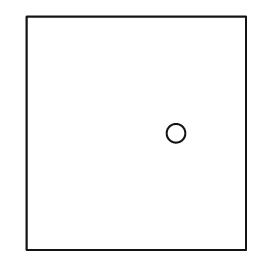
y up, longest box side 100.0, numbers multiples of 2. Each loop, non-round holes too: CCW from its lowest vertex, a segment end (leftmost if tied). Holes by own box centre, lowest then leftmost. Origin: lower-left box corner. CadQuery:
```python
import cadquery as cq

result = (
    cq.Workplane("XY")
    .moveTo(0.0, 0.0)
    .lineTo(94.0, 0.0)
    .lineTo(94.0, 100.0)
    .lineTo(0.0, 100.0)
    .close()
    .moveTo(64.0, 50.0)
    .circle(4.0)
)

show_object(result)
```